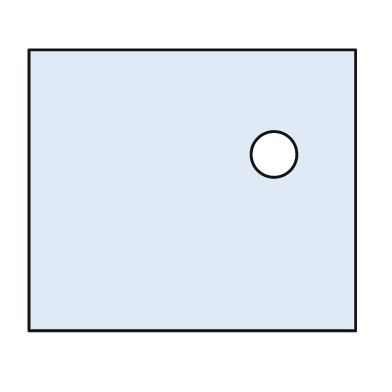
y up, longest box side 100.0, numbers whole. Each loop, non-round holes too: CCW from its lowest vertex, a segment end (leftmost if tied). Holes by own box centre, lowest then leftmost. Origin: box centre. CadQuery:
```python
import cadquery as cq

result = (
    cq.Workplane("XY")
    .moveTo(-50.0, -43.0)
    .lineTo(50.0, -43.0)
    .lineTo(50.0, 43.0)
    .lineTo(-50.0, 43.0)
    .close()
    .moveTo(25.0, 11.0)
    .circle(7.0)
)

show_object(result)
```